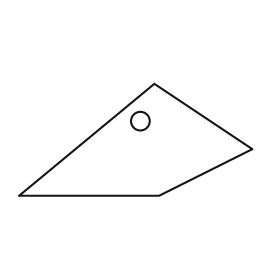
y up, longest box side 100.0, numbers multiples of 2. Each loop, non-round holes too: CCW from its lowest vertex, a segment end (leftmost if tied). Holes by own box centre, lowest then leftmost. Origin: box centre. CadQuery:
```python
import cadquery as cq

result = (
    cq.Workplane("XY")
    .moveTo(-50.0, -24.0)
    .lineTo(10.0, -24.0)
    .lineTo(50.0, -4.0)
    .lineTo(8.0, 24.0)
    .close()
    .moveTo(2.0, 8.0)
    .circle(4.0)
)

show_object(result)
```